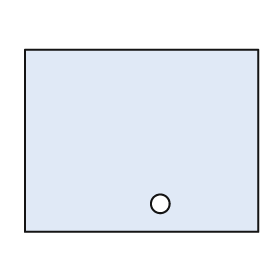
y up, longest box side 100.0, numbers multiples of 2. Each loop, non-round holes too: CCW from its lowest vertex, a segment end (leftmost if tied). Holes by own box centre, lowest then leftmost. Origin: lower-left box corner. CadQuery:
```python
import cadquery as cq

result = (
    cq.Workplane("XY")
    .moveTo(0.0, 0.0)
    .lineTo(100.0, 0.0)
    .lineTo(100.0, 78.0)
    .lineTo(0.0, 78.0)
    .close()
    .moveTo(58.0, 12.0)
    .circle(4.0)
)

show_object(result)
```